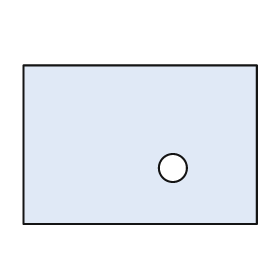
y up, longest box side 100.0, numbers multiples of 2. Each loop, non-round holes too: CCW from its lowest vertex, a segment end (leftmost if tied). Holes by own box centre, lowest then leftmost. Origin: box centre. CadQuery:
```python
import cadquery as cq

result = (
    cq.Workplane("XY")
    .moveTo(-50.0, -34.0)
    .lineTo(50.0, -34.0)
    .lineTo(50.0, 34.0)
    .lineTo(-50.0, 34.0)
    .close()
    .moveTo(14.0, -10.0)
    .circle(6.0)
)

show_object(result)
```